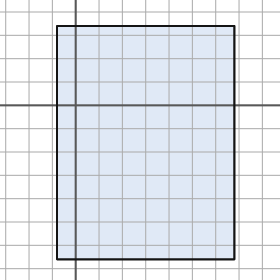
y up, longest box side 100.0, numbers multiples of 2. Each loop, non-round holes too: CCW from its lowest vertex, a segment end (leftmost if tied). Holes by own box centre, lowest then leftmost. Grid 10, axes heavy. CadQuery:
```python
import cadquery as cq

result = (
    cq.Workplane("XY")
    .moveTo(-8.0, -66.0)
    .lineTo(68.0, -66.0)
    .lineTo(68.0, 34.0)
    .lineTo(-8.0, 34.0)
    .close()
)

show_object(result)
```